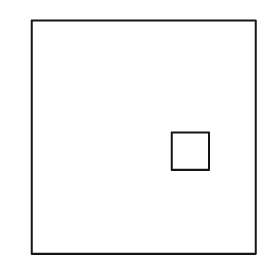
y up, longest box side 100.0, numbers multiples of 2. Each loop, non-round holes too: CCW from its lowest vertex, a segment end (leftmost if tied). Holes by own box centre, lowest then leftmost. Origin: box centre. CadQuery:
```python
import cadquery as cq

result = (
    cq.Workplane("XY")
    .moveTo(-48.0, -50.0)
    .lineTo(48.0, -50.0)
    .lineTo(48.0, 50.0)
    .lineTo(-48.0, 50.0)
    .close()
    .moveTo(12.0, -14.0)
    .lineTo(28.0, -14.0)
    .lineTo(28.0, 2.0)
    .lineTo(12.0, 2.0)
    .close()
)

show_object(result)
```